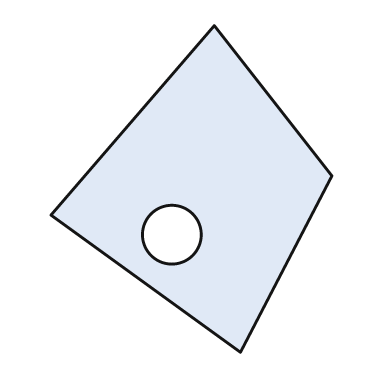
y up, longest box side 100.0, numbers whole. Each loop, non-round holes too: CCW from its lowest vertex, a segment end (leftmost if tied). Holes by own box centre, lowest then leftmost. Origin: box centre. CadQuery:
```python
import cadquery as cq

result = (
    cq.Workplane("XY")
    .moveTo(15.0, -50.0)
    .lineTo(43.0, 4.0)
    .lineTo(7.0, 50.0)
    .lineTo(-43.0, -8.0)
    .close()
    .moveTo(-6.0, -14.0)
    .circle(9.0)
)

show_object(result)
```